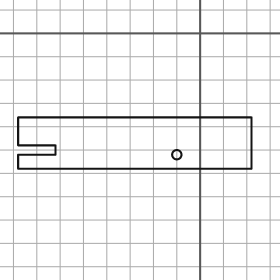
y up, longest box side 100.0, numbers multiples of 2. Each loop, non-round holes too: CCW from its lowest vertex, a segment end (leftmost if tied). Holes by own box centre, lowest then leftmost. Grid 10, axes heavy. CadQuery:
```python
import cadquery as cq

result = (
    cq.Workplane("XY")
    .moveTo(-78.0, -58.0)
    .lineTo(22.0, -58.0)
    .lineTo(22.0, -36.0)
    .lineTo(-78.0, -36.0)
    .lineTo(-78.0, -48.0)
    .lineTo(-62.0, -48.0)
    .lineTo(-62.0, -52.0)
    .lineTo(-78.0, -52.0)
    .close()
    .moveTo(-10.0, -52.0)
    .circle(2.0)
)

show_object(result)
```